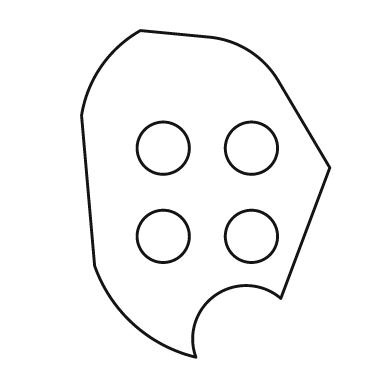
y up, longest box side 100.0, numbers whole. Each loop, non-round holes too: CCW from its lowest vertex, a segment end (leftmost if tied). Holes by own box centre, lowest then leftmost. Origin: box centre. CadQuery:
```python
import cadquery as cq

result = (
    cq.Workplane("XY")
    .moveTo(-3.0, -50.0)
    .threePointArc((3.0, -31.0), (23.0, -32.0))
    .lineTo(38.0, 8.0)
    .lineTo(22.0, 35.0)
    .threePointArc((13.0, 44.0), (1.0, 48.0))
    .lineTo(-20.0, 50.0)
    .threePointArc((-32.0, 39.0), (-38.0, 24.0))
    .lineTo(-34.0, -22.0)
    .threePointArc((-22.0, -40.0), (-3.0, -50.0))
    .close()
    .moveTo(-13.0, -13.0)
    .circle(8.0)
    .moveTo(14.0, -13.0)
    .circle(8.0)
    .moveTo(-13.0, 14.0)
    .circle(8.0)
    .moveTo(14.0, 14.0)
    .circle(8.0)
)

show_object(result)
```